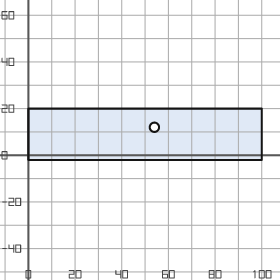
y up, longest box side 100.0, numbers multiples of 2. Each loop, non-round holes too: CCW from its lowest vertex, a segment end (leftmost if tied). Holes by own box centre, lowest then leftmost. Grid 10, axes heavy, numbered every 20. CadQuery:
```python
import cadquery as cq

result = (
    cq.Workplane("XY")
    .moveTo(0.0, -2.0)
    .lineTo(100.0, -2.0)
    .lineTo(100.0, 20.0)
    .lineTo(0.0, 20.0)
    .close()
    .moveTo(54.0, 12.0)
    .circle(2.0)
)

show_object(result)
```